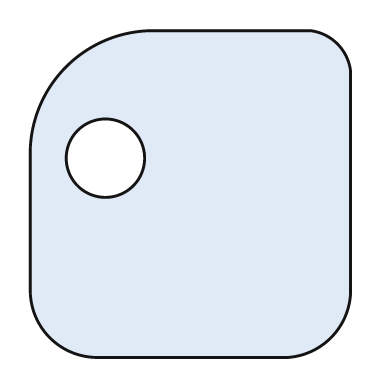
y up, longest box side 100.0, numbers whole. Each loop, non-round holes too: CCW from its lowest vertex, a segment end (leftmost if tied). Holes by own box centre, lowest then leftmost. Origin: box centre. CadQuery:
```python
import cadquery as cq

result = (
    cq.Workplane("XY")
    .moveTo(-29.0, -50.0)
    .lineTo(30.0, -50.0)
    .threePointArc((43.0, -44.0), (49.0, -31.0))
    .lineTo(49.0, 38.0)
    .threePointArc((45.0, 46.0), (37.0, 50.0))
    .lineTo(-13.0, 50.0)
    .threePointArc((-38.0, 39.0), (-49.0, 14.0))
    .lineTo(-49.0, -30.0)
    .threePointArc((-43.0, -44.0), (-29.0, -50.0))
    .close()
    .moveTo(-26.0, 11.0)
    .circle(12.0)
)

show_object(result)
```